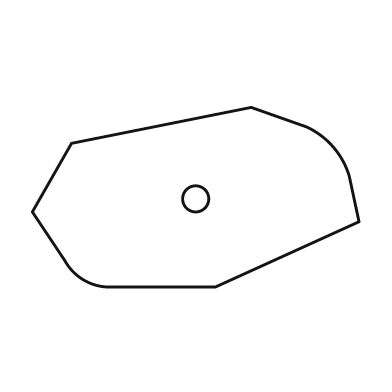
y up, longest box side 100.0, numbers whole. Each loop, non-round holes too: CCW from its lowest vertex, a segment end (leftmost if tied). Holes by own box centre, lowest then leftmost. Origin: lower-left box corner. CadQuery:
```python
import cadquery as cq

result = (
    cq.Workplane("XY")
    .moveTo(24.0, 0.0)
    .lineTo(56.0, 0.0)
    .lineTo(100.0, 20.0)
    .lineTo(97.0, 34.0)
    .threePointArc((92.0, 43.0), (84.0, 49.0))
    .lineTo(67.0, 55.0)
    .lineTo(12.0, 44.0)
    .lineTo(0.0, 23.0)
    .lineTo(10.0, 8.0)
    .threePointArc((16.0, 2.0), (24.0, 0.0))
    .close()
    .moveTo(50.0, 27.0)
    .circle(4.0)
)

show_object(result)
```